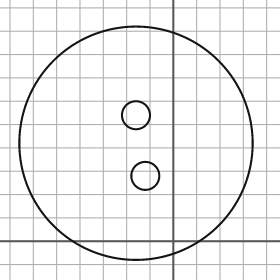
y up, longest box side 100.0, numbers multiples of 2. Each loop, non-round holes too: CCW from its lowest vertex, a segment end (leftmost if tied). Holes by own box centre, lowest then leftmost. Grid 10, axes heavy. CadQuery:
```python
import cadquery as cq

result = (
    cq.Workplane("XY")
    .moveTo(-16.0, 42.0)
    .circle(50.0)
    .moveTo(-12.0, 28.0)
    .circle(6.0)
    .moveTo(-16.0, 54.0)
    .circle(6.0)
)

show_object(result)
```